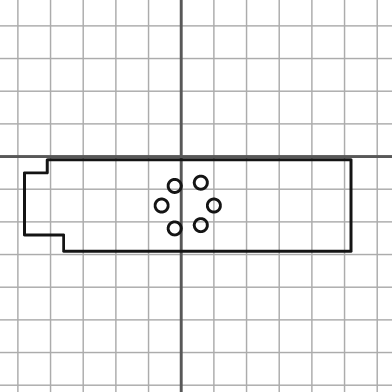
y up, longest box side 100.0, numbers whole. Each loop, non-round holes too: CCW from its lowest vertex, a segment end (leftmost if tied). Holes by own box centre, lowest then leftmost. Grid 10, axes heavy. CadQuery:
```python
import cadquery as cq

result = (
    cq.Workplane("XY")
    .moveTo(-36.0, -29.0)
    .lineTo(52.0, -29.0)
    .lineTo(52.0, -1.0)
    .lineTo(-41.0, -1.0)
    .lineTo(-41.0, -5.0)
    .lineTo(-48.0, -5.0)
    .lineTo(-48.0, -24.0)
    .lineTo(-36.0, -24.0)
    .close()
    .moveTo(-2.0, -22.0)
    .circle(2.0)
    .moveTo(6.0, -21.0)
    .circle(2.0)
    .moveTo(-6.0, -15.0)
    .circle(2.0)
    .moveTo(10.0, -15.0)
    .circle(2.0)
    .moveTo(-2.0, -9.0)
    .circle(2.0)
    .moveTo(6.0, -8.0)
    .circle(2.0)
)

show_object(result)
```